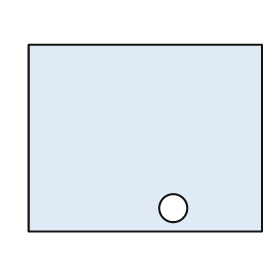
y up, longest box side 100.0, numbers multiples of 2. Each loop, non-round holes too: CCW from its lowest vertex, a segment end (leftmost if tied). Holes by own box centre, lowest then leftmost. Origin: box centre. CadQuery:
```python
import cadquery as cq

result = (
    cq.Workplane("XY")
    .moveTo(-50.0, -40.0)
    .lineTo(50.0, -40.0)
    .lineTo(50.0, 40.0)
    .lineTo(-50.0, 40.0)
    .close()
    .moveTo(12.0, -30.0)
    .circle(6.0)
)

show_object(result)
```